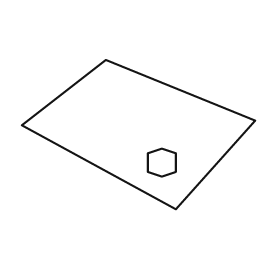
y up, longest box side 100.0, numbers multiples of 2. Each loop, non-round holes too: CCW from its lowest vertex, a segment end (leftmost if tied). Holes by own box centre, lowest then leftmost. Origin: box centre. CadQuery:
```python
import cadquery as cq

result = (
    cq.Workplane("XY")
    .moveTo(16.0, -32.0)
    .lineTo(50.0, 6.0)
    .lineTo(-14.0, 32.0)
    .lineTo(-50.0, 4.0)
    .close()
    .moveTo(10.0, -18.0)
    .lineTo(16.0, -16.0)
    .lineTo(16.0, -8.0)
    .lineTo(10.0, -6.0)
    .lineTo(4.0, -8.0)
    .lineTo(4.0, -16.0)
    .close()
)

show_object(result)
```